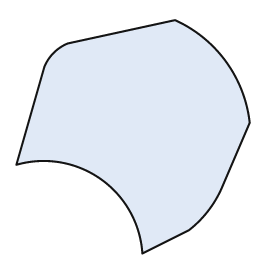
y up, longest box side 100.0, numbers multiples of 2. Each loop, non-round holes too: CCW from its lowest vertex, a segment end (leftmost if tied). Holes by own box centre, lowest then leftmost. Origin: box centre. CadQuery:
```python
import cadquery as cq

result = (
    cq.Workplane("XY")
    .moveTo(4.0, -50.0)
    .lineTo(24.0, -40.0)
    .threePointArc((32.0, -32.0), (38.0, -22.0))
    .lineTo(50.0, 6.0)
    .threePointArc((40.0, 32.0), (18.0, 50.0))
    .lineTo(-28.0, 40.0)
    .threePointArc((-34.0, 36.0), (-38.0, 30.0))
    .lineTo(-50.0, -12.0)
    .threePointArc((-14.0, -18.0), (4.0, -50.0))
    .close()
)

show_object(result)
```